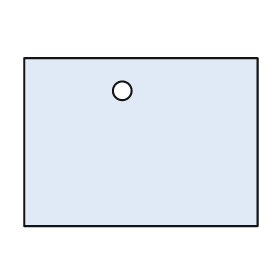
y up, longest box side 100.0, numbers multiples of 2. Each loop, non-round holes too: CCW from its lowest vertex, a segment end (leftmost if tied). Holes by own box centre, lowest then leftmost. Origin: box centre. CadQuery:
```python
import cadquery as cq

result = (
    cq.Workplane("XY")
    .moveTo(-50.0, -36.0)
    .lineTo(50.0, -36.0)
    .lineTo(50.0, 36.0)
    .lineTo(-50.0, 36.0)
    .close()
    .moveTo(-8.0, 22.0)
    .circle(4.0)
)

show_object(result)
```